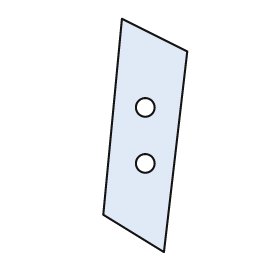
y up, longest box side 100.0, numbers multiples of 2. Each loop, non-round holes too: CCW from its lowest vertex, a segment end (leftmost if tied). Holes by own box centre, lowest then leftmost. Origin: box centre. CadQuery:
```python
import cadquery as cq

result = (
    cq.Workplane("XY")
    .moveTo(8.0, -50.0)
    .lineTo(18.0, 36.0)
    .lineTo(-10.0, 50.0)
    .lineTo(-18.0, -34.0)
    .close()
    .moveTo(0.0, -12.0)
    .circle(4.0)
    .moveTo(0.0, 12.0)
    .circle(4.0)
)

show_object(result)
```